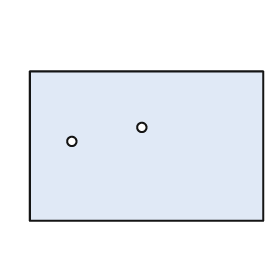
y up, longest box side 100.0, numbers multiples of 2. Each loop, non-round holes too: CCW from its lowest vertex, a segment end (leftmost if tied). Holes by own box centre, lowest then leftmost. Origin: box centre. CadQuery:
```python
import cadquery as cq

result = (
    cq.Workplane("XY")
    .moveTo(-50.0, -32.0)
    .lineTo(50.0, -32.0)
    .lineTo(50.0, 32.0)
    .lineTo(-50.0, 32.0)
    .close()
    .moveTo(-32.0, 2.0)
    .circle(2.0)
    .moveTo(-2.0, 8.0)
    .circle(2.0)
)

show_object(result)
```